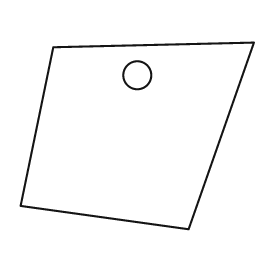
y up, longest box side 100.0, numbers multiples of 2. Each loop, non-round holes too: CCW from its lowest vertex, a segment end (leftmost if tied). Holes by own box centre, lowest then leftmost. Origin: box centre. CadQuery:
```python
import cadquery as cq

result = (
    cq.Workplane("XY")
    .moveTo(22.0, -40.0)
    .lineTo(50.0, 40.0)
    .lineTo(-36.0, 38.0)
    .lineTo(-50.0, -30.0)
    .close()
    .moveTo(0.0, 26.0)
    .circle(6.0)
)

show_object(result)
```